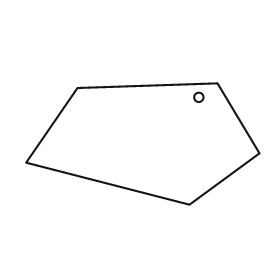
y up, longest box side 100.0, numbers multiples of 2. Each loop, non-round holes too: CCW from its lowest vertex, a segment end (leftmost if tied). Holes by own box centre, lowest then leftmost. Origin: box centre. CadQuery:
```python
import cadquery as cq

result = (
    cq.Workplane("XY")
    .moveTo(20.0, -26.0)
    .lineTo(50.0, -4.0)
    .lineTo(32.0, 26.0)
    .lineTo(-28.0, 24.0)
    .lineTo(-50.0, -8.0)
    .close()
    .moveTo(24.0, 20.0)
    .circle(2.0)
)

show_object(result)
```